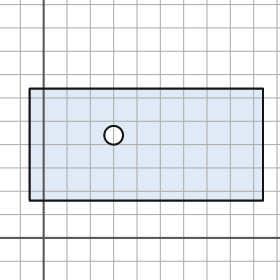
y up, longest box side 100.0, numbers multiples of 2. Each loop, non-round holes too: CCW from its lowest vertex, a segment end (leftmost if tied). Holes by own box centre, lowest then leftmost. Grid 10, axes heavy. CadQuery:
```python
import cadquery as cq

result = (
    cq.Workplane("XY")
    .moveTo(-6.0, 16.0)
    .lineTo(94.0, 16.0)
    .lineTo(94.0, 64.0)
    .lineTo(-6.0, 64.0)
    .close()
    .moveTo(30.0, 44.0)
    .circle(4.0)
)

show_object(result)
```